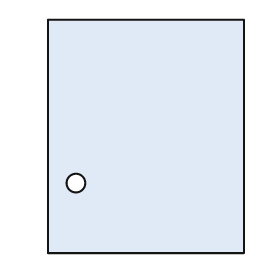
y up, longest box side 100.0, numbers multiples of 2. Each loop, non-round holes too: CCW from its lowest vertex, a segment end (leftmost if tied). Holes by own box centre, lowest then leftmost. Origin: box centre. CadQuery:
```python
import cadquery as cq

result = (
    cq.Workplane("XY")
    .moveTo(-42.0, -50.0)
    .lineTo(42.0, -50.0)
    .lineTo(42.0, 50.0)
    .lineTo(-42.0, 50.0)
    .close()
    .moveTo(-30.0, -20.0)
    .circle(4.0)
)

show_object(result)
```